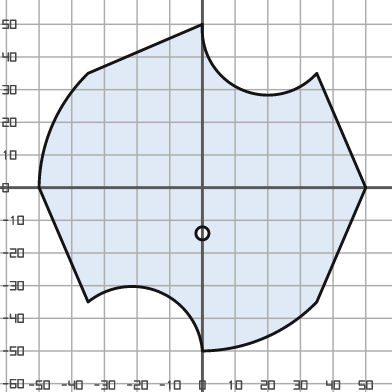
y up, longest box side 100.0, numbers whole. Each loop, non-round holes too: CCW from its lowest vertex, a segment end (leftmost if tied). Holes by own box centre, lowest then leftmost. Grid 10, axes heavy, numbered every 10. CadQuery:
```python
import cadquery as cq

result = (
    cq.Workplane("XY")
    .moveTo(0.0, -50.0)
    .threePointArc((19.0, -46.0), (35.0, -35.0))
    .lineTo(50.0, 0.0)
    .lineTo(35.0, 35.0)
    .threePointArc((12.0, 30.0), (0.0, 50.0))
    .lineTo(-35.0, 35.0)
    .threePointArc((-46.0, 19.0), (-50.0, 0.0))
    .lineTo(-35.0, -35.0)
    .threePointArc((-13.0, -32.0), (0.0, -50.0))
    .close()
    .moveTo(0.0, -14.0)
    .circle(2.0)
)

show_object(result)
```